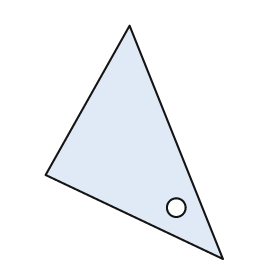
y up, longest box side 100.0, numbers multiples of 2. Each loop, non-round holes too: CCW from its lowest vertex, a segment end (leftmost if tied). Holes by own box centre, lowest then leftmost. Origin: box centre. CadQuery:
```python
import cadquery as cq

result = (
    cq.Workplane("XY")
    .moveTo(38.0, -50.0)
    .lineTo(-2.0, 50.0)
    .lineTo(-38.0, -14.0)
    .close()
    .moveTo(18.0, -28.0)
    .circle(4.0)
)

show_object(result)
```